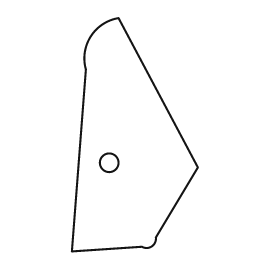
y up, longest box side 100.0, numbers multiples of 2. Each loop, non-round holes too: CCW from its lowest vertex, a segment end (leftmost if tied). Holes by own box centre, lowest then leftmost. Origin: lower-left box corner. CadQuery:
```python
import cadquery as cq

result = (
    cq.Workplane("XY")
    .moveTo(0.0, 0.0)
    .lineTo(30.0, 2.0)
    .threePointArc((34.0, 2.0), (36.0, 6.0))
    .lineTo(54.0, 36.0)
    .lineTo(20.0, 100.0)
    .threePointArc((8.0, 92.0), (6.0, 78.0))
    .close()
    .moveTo(16.0, 38.0)
    .circle(4.0)
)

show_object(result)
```